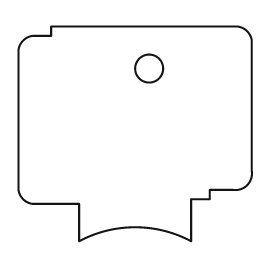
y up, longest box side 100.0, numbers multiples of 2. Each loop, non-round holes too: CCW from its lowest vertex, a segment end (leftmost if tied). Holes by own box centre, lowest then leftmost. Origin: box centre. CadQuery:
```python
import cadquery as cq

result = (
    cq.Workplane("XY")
    .moveTo(-24.0, -46.0)
    .threePointArc((0.0, -40.0), (24.0, -46.0))
    .lineTo(24.0, -28.0)
    .lineTo(32.0, -28.0)
    .lineTo(32.0, -24.0)
    .lineTo(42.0, -24.0)
    .threePointArc((48.0, -22.0), (50.0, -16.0))
    .lineTo(50.0, 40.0)
    .threePointArc((48.0, 44.0), (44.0, 46.0))
    .lineTo(-36.0, 46.0)
    .lineTo(-36.0, 42.0)
    .lineTo(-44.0, 42.0)
    .threePointArc((-48.0, 40.0), (-50.0, 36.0))
    .lineTo(-50.0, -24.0)
    .threePointArc((-48.0, -28.0), (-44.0, -30.0))
    .lineTo(-24.0, -30.0)
    .close()
    .moveTo(6.0, 28.0)
    .circle(6.0)
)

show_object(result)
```